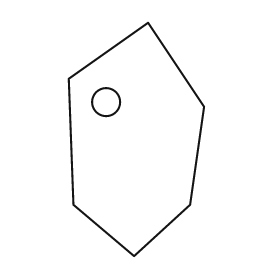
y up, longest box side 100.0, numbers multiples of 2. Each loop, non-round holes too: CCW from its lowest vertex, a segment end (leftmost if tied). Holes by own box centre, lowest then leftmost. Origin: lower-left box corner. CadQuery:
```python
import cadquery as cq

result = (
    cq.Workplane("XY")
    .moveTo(28.0, 0.0)
    .lineTo(52.0, 22.0)
    .lineTo(58.0, 64.0)
    .lineTo(34.0, 100.0)
    .lineTo(0.0, 76.0)
    .lineTo(2.0, 22.0)
    .close()
    .moveTo(16.0, 66.0)
    .circle(6.0)
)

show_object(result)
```